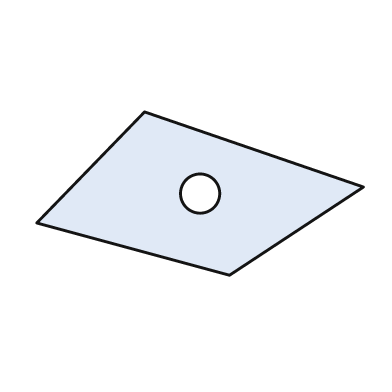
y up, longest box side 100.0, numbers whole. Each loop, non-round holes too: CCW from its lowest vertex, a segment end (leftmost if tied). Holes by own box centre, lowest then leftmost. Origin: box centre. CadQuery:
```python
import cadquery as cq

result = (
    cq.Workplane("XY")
    .moveTo(9.0, -25.0)
    .lineTo(50.0, 2.0)
    .lineTo(-17.0, 25.0)
    .lineTo(-50.0, -9.0)
    .close()
    .moveTo(0.0, 0.0)
    .circle(6.0)
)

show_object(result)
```